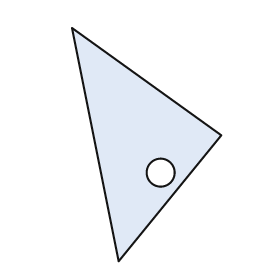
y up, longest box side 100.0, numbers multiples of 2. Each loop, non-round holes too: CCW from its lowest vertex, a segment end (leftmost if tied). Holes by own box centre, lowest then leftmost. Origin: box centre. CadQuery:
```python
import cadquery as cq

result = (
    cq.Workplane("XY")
    .moveTo(-12.0, -50.0)
    .lineTo(32.0, 4.0)
    .lineTo(-32.0, 50.0)
    .close()
    .moveTo(6.0, -12.0)
    .circle(6.0)
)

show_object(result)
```